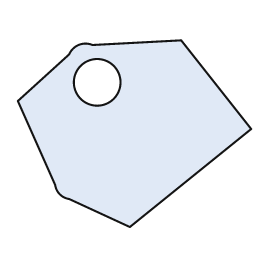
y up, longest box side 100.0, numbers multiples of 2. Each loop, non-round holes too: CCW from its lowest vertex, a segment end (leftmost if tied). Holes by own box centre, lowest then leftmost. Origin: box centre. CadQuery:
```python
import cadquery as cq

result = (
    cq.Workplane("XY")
    .moveTo(-2.0, -40.0)
    .lineTo(50.0, 2.0)
    .lineTo(20.0, 40.0)
    .lineTo(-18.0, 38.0)
    .threePointArc((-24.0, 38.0), (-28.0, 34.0))
    .lineTo(-50.0, 14.0)
    .lineTo(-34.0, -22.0)
    .threePointArc((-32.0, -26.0), (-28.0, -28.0))
    .close()
    .moveTo(-16.0, 22.0)
    .circle(10.0)
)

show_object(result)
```